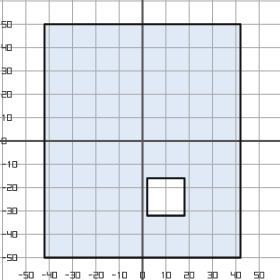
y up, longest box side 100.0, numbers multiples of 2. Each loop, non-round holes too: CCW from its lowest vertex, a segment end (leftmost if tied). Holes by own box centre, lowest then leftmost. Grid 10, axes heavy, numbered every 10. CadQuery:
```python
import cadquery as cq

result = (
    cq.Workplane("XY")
    .moveTo(-42.0, -50.0)
    .lineTo(42.0, -50.0)
    .lineTo(42.0, 50.0)
    .lineTo(-42.0, 50.0)
    .close()
    .moveTo(2.0, -32.0)
    .lineTo(18.0, -32.0)
    .lineTo(18.0, -16.0)
    .lineTo(2.0, -16.0)
    .close()
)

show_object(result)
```